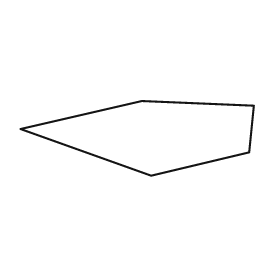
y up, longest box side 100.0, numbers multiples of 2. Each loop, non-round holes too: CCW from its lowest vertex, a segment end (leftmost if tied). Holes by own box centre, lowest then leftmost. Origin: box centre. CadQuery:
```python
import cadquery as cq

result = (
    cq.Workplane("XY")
    .moveTo(6.0, -16.0)
    .lineTo(48.0, -6.0)
    .lineTo(50.0, 14.0)
    .lineTo(2.0, 16.0)
    .lineTo(-50.0, 4.0)
    .close()
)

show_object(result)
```